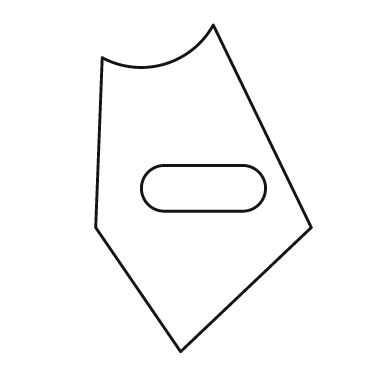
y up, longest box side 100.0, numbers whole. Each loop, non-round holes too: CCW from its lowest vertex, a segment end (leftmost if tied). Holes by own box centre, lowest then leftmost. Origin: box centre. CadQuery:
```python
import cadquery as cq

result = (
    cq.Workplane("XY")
    .moveTo(-7.0, -50.0)
    .lineTo(33.0, -12.0)
    .lineTo(3.0, 50.0)
    .threePointArc((-12.0, 38.0), (-31.0, 40.0))
    .lineTo(-33.0, -12.0)
    .close()
    .moveTo(-12.0, -7.0)
    .lineTo(12.0, -7.0)
    .threePointArc((19.0, 0.0), (12.0, 7.0))
    .lineTo(-12.0, 7.0)
    .threePointArc((-19.0, 0.0), (-12.0, -7.0))
    .close()
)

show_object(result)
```